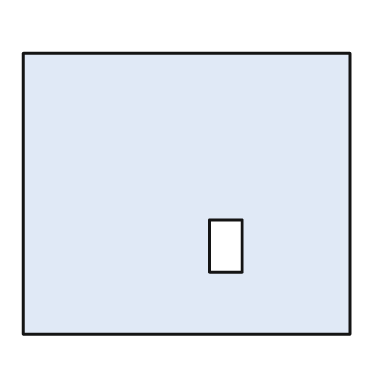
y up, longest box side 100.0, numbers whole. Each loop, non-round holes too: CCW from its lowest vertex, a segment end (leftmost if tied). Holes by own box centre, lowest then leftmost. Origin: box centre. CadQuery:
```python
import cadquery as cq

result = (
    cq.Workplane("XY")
    .moveTo(-50.0, -43.0)
    .lineTo(50.0, -43.0)
    .lineTo(50.0, 43.0)
    .lineTo(-50.0, 43.0)
    .close()
    .moveTo(7.0, -24.0)
    .lineTo(17.0, -24.0)
    .lineTo(17.0, -8.0)
    .lineTo(7.0, -8.0)
    .close()
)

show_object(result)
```